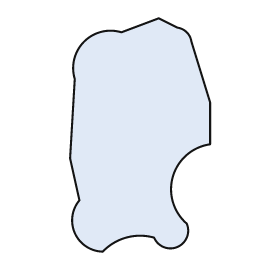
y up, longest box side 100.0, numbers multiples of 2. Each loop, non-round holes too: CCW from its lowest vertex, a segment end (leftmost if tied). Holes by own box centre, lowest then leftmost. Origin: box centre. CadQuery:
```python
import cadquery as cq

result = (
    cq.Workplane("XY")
    .moveTo(-16.0, -50.0)
    .threePointArc((-6.0, -44.0), (6.0, -44.0))
    .threePointArc((16.0, -48.0), (20.0, -38.0))
    .threePointArc((14.0, -18.0), (30.0, -4.0))
    .lineTo(30.0, 14.0)
    .lineTo(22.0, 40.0)
    .threePointArc((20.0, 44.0), (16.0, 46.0))
    .lineTo(8.0, 50.0)
    .lineTo(-8.0, 44.0)
    .threePointArc((-24.0, 40.0), (-28.0, 24.0))
    .lineTo(-30.0, -10.0)
    .lineTo(-26.0, -28.0)
    .threePointArc((-28.0, -42.0), (-16.0, -50.0))
    .close()
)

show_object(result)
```